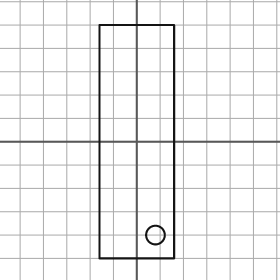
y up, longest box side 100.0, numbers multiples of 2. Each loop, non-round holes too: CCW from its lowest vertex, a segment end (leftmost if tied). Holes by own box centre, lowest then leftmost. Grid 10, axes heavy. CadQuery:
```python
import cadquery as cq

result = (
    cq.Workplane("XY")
    .moveTo(-16.0, -50.0)
    .lineTo(16.0, -50.0)
    .lineTo(16.0, 50.0)
    .lineTo(-16.0, 50.0)
    .close()
    .moveTo(8.0, -40.0)
    .circle(4.0)
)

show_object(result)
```